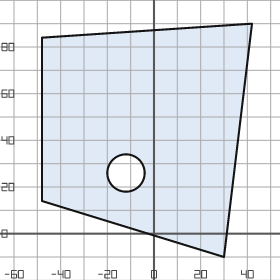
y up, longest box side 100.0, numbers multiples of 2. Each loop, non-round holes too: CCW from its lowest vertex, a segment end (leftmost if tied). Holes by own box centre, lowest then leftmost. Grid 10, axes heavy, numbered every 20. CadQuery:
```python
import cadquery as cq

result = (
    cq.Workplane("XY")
    .moveTo(30.0, -10.0)
    .lineTo(42.0, 90.0)
    .lineTo(-48.0, 84.0)
    .lineTo(-48.0, 14.0)
    .close()
    .moveTo(-12.0, 26.0)
    .circle(8.0)
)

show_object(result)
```